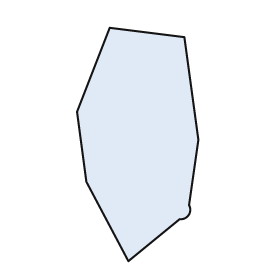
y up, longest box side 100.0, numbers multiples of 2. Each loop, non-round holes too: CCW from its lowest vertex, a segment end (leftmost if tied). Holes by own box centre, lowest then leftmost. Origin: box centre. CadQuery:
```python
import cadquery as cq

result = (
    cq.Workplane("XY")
    .moveTo(-4.0, -50.0)
    .lineTo(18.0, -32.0)
    .threePointArc((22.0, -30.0), (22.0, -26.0))
    .lineTo(26.0, 2.0)
    .lineTo(20.0, 46.0)
    .lineTo(-12.0, 50.0)
    .lineTo(-26.0, 14.0)
    .lineTo(-22.0, -16.0)
    .close()
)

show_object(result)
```